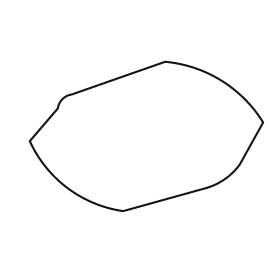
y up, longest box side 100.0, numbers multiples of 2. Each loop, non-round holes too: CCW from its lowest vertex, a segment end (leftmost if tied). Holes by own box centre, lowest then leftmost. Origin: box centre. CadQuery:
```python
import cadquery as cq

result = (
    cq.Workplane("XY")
    .moveTo(-10.0, -32.0)
    .lineTo(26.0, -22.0)
    .threePointArc((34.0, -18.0), (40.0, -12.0))
    .lineTo(50.0, 6.0)
    .threePointArc((32.0, 24.0), (8.0, 32.0))
    .lineTo(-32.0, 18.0)
    .threePointArc((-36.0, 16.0), (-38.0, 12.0))
    .lineTo(-50.0, -2.0)
    .threePointArc((-34.0, -22.0), (-10.0, -32.0))
    .close()
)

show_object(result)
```